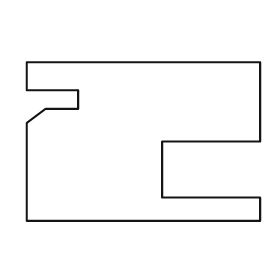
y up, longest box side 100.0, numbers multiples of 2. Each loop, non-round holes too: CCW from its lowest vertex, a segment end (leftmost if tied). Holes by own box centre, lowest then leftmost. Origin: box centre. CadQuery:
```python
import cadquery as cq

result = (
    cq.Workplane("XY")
    .moveTo(-50.0, -34.0)
    .lineTo(50.0, -34.0)
    .lineTo(50.0, -24.0)
    .lineTo(8.0, -24.0)
    .lineTo(8.0, 0.0)
    .lineTo(50.0, 0.0)
    .lineTo(50.0, 34.0)
    .lineTo(-50.0, 34.0)
    .lineTo(-50.0, 22.0)
    .lineTo(-28.0, 22.0)
    .lineTo(-28.0, 14.0)
    .lineTo(-42.0, 14.0)
    .lineTo(-50.0, 8.0)
    .close()
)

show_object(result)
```